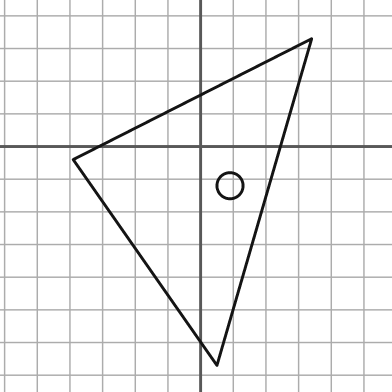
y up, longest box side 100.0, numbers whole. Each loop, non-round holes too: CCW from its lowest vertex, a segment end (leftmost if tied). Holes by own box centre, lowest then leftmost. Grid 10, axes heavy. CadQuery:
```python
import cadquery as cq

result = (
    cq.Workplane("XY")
    .moveTo(5.0, -67.0)
    .lineTo(34.0, 33.0)
    .lineTo(-39.0, -4.0)
    .close()
    .moveTo(9.0, -12.0)
    .circle(4.0)
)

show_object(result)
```